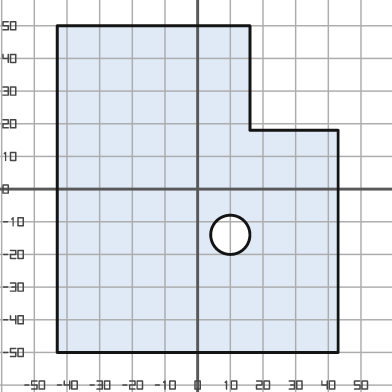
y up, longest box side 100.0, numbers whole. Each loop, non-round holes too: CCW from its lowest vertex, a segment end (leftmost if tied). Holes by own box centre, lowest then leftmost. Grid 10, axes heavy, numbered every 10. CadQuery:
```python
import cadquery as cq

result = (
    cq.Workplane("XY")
    .moveTo(-43.0, -50.0)
    .lineTo(43.0, -50.0)
    .lineTo(43.0, 18.0)
    .lineTo(16.0, 18.0)
    .lineTo(16.0, 50.0)
    .lineTo(-43.0, 50.0)
    .close()
    .moveTo(10.0, -14.0)
    .circle(6.0)
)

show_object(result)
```